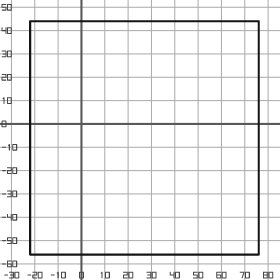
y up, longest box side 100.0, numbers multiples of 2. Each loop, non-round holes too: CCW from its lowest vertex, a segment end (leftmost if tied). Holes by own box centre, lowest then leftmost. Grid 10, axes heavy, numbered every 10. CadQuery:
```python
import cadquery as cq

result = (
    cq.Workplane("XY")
    .moveTo(-22.0, -56.0)
    .lineTo(76.0, -56.0)
    .lineTo(76.0, 44.0)
    .lineTo(-22.0, 44.0)
    .close()
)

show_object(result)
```